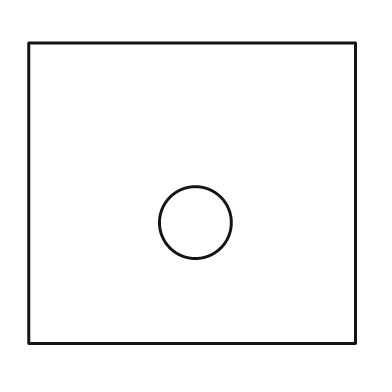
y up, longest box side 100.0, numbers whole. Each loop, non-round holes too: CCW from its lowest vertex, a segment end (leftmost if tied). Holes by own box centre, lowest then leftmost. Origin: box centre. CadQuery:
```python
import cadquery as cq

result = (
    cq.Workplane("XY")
    .moveTo(-50.0, -46.0)
    .lineTo(50.0, -46.0)
    .lineTo(50.0, 46.0)
    .lineTo(-50.0, 46.0)
    .close()
    .moveTo(1.0, -9.0)
    .circle(11.0)
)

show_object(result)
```